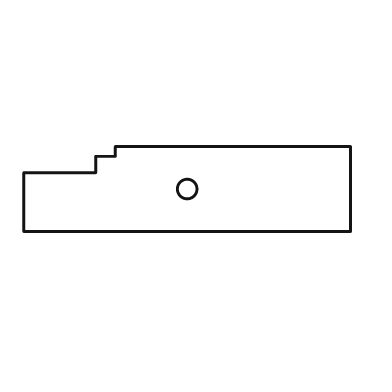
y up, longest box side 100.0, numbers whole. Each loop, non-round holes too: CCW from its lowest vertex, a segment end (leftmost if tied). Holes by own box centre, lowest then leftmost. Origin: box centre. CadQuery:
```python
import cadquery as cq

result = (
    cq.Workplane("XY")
    .moveTo(-50.0, -13.0)
    .lineTo(50.0, -13.0)
    .lineTo(50.0, 13.0)
    .lineTo(-22.0, 13.0)
    .lineTo(-22.0, 10.0)
    .lineTo(-28.0, 10.0)
    .lineTo(-28.0, 5.0)
    .lineTo(-50.0, 5.0)
    .close()
    .moveTo(0.0, 0.0)
    .circle(3.0)
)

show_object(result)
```